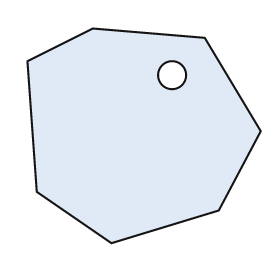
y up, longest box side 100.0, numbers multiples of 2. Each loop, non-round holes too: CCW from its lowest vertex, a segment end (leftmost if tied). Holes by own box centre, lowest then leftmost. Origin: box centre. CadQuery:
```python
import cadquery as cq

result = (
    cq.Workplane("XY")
    .moveTo(-14.0, -46.0)
    .lineTo(32.0, -32.0)
    .lineTo(50.0, 2.0)
    .lineTo(26.0, 42.0)
    .lineTo(-22.0, 46.0)
    .lineTo(-50.0, 32.0)
    .lineTo(-46.0, -24.0)
    .close()
    .moveTo(12.0, 26.0)
    .circle(6.0)
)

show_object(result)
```